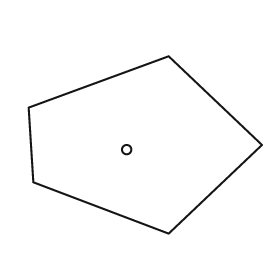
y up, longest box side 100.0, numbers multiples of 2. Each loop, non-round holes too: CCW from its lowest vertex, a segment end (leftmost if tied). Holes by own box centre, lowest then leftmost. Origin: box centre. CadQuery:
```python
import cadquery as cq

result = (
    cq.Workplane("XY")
    .moveTo(10.0, -38.0)
    .lineTo(50.0, 0.0)
    .lineTo(10.0, 38.0)
    .lineTo(-50.0, 16.0)
    .lineTo(-48.0, -16.0)
    .close()
    .moveTo(-8.0, -2.0)
    .circle(2.0)
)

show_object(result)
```